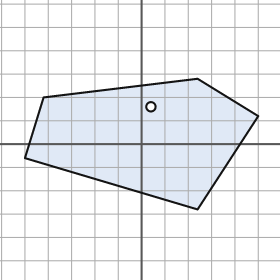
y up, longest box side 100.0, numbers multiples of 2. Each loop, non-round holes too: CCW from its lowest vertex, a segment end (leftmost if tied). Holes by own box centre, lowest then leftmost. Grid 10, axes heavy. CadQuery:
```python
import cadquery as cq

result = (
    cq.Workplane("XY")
    .moveTo(24.0, -28.0)
    .lineTo(50.0, 12.0)
    .lineTo(24.0, 28.0)
    .lineTo(-42.0, 20.0)
    .lineTo(-50.0, -6.0)
    .close()
    .moveTo(4.0, 16.0)
    .circle(2.0)
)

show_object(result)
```